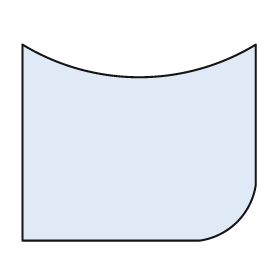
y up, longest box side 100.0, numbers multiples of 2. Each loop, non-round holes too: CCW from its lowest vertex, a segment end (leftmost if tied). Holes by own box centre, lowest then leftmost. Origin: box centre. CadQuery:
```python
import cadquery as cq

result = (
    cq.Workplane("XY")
    .moveTo(-50.0, -42.0)
    .lineTo(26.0, -42.0)
    .threePointArc((42.0, -34.0), (50.0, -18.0))
    .lineTo(50.0, 42.0)
    .threePointArc((0.0, 28.0), (-50.0, 42.0))
    .close()
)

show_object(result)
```